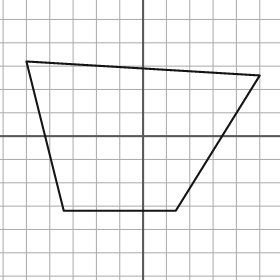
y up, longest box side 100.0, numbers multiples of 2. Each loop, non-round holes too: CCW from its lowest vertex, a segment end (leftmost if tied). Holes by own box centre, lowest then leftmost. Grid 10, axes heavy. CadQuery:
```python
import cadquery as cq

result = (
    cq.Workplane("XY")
    .moveTo(-34.0, -32.0)
    .lineTo(14.0, -32.0)
    .lineTo(50.0, 26.0)
    .lineTo(-50.0, 32.0)
    .close()
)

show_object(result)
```